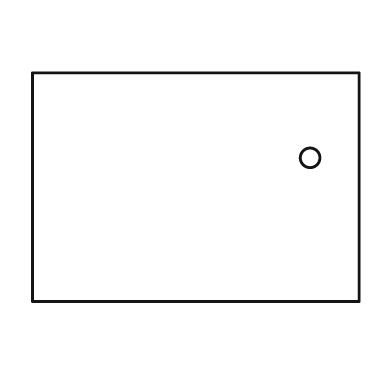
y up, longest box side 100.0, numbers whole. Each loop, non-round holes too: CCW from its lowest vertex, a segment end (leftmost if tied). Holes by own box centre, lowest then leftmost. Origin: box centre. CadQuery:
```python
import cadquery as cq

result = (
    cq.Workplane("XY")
    .moveTo(-50.0, -35.0)
    .lineTo(50.0, -35.0)
    .lineTo(50.0, 35.0)
    .lineTo(-50.0, 35.0)
    .close()
    .moveTo(35.0, 9.0)
    .circle(3.0)
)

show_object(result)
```